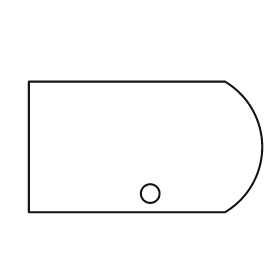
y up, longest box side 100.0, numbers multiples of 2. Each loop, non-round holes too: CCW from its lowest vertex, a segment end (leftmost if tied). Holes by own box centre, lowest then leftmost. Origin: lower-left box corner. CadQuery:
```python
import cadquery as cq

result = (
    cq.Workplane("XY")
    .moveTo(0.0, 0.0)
    .lineTo(84.0, 0.0)
    .threePointArc((100.0, 28.0), (84.0, 56.0))
    .lineTo(0.0, 56.0)
    .close()
    .moveTo(52.0, 8.0)
    .circle(4.0)
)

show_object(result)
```